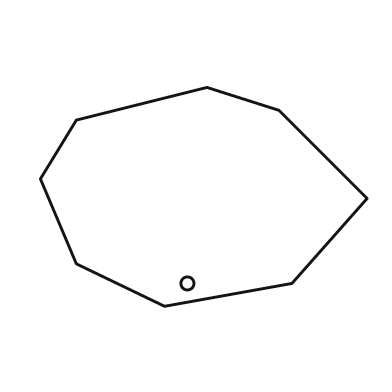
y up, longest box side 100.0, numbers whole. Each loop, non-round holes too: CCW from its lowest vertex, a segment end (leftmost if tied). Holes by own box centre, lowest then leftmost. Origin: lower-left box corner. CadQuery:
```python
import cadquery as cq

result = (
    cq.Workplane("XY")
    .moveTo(38.0, 0.0)
    .lineTo(77.0, 7.0)
    .lineTo(100.0, 33.0)
    .lineTo(73.0, 60.0)
    .lineTo(51.0, 67.0)
    .lineTo(11.0, 57.0)
    .lineTo(0.0, 39.0)
    .lineTo(11.0, 13.0)
    .close()
    .moveTo(45.0, 7.0)
    .circle(2.0)
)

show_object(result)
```